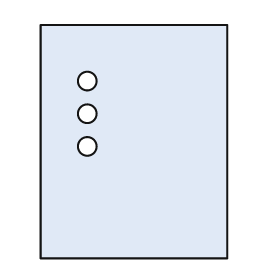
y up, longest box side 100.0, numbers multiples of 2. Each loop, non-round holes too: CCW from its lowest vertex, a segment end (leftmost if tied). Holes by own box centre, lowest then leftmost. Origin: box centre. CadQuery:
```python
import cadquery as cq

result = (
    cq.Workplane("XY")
    .moveTo(-40.0, -50.0)
    .lineTo(40.0, -50.0)
    .lineTo(40.0, 50.0)
    .lineTo(-40.0, 50.0)
    .close()
    .moveTo(-20.0, -2.0)
    .circle(4.0)
    .moveTo(-20.0, 12.0)
    .circle(4.0)
    .moveTo(-20.0, 26.0)
    .circle(4.0)
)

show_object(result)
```